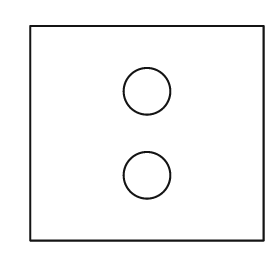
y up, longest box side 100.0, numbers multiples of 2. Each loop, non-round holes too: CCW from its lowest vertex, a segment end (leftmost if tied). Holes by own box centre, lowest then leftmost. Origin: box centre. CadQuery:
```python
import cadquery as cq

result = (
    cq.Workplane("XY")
    .moveTo(-50.0, -46.0)
    .lineTo(50.0, -46.0)
    .lineTo(50.0, 46.0)
    .lineTo(-50.0, 46.0)
    .close()
    .moveTo(0.0, -18.0)
    .circle(10.0)
    .moveTo(0.0, 18.0)
    .circle(10.0)
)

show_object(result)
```